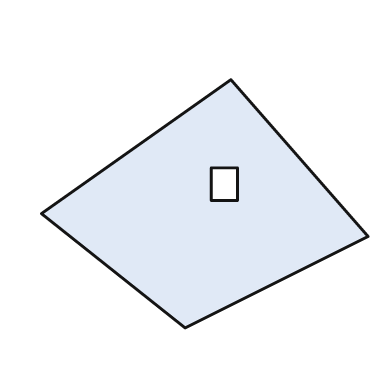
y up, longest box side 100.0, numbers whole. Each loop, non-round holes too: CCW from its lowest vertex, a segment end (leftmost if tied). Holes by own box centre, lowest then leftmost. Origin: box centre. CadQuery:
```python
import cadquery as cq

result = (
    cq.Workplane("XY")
    .moveTo(-6.0, -38.0)
    .lineTo(50.0, -10.0)
    .lineTo(8.0, 38.0)
    .lineTo(-50.0, -3.0)
    .close()
    .moveTo(2.0, 1.0)
    .lineTo(10.0, 1.0)
    .lineTo(10.0, 11.0)
    .lineTo(2.0, 11.0)
    .close()
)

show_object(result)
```